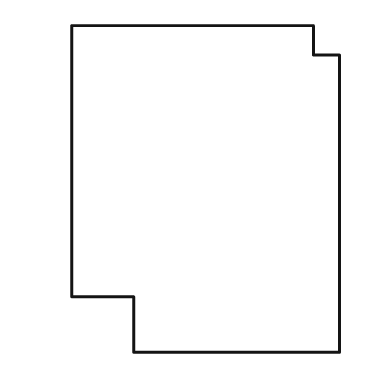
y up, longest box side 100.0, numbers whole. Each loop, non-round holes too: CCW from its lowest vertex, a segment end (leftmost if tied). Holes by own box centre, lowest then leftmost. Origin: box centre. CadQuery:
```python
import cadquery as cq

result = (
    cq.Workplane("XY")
    .moveTo(-22.0, -50.0)
    .lineTo(41.0, -50.0)
    .lineTo(41.0, 41.0)
    .lineTo(33.0, 41.0)
    .lineTo(33.0, 50.0)
    .lineTo(-41.0, 50.0)
    .lineTo(-41.0, -33.0)
    .lineTo(-22.0, -33.0)
    .close()
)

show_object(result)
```